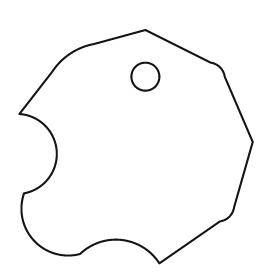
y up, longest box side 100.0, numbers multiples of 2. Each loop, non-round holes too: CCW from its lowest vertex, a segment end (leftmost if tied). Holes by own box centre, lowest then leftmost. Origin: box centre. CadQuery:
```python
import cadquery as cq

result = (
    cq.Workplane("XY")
    .moveTo(10.0, -50.0)
    .lineTo(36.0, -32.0)
    .threePointArc((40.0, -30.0), (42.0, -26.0))
    .lineTo(50.0, 2.0)
    .lineTo(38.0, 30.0)
    .threePointArc((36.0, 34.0), (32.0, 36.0))
    .lineTo(4.0, 50.0)
    .lineTo(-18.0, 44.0)
    .threePointArc((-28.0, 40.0), (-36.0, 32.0))
    .lineTo(-50.0, 14.0)
    .threePointArc((-34.0, -2.0), (-48.0, -20.0))
    .threePointArc((-44.0, -40.0), (-24.0, -46.0))
    .threePointArc((-6.0, -40.0), (10.0, -50.0))
    .close()
    .moveTo(4.0, 30.0)
    .circle(6.0)
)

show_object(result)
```